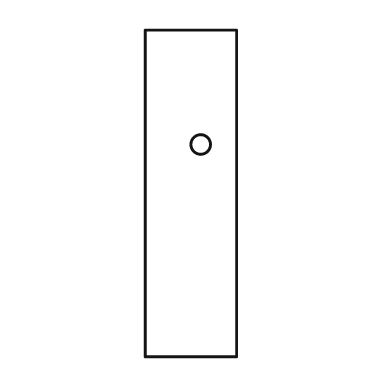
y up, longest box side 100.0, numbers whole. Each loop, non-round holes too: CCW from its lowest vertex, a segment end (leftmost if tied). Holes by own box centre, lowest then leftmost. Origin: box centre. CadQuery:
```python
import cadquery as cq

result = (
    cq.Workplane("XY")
    .moveTo(-14.0, -50.0)
    .lineTo(14.0, -50.0)
    .lineTo(14.0, 50.0)
    .lineTo(-14.0, 50.0)
    .close()
    .moveTo(3.0, 15.0)
    .circle(3.0)
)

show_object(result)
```